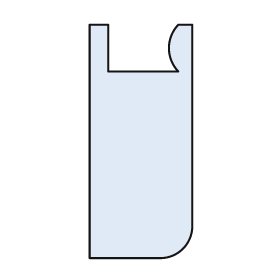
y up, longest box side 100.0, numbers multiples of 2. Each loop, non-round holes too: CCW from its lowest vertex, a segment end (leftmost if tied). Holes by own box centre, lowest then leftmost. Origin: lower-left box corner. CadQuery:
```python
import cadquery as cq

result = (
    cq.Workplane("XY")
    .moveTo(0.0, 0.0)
    .lineTo(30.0, 0.0)
    .threePointArc((40.0, 4.0), (44.0, 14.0))
    .lineTo(44.0, 100.0)
    .lineTo(38.0, 100.0)
    .threePointArc((34.0, 90.0), (38.0, 80.0))
    .lineTo(8.0, 80.0)
    .lineTo(8.0, 100.0)
    .lineTo(0.0, 100.0)
    .close()
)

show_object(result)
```